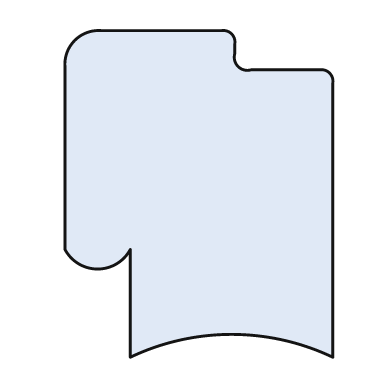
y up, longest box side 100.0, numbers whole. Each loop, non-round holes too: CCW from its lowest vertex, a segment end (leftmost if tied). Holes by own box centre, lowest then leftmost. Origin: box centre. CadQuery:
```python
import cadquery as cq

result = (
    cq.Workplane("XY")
    .moveTo(-21.0, -50.0)
    .threePointArc((10.0, -43.0), (41.0, -50.0))
    .lineTo(41.0, 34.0)
    .threePointArc((40.0, 37.0), (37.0, 38.0))
    .lineTo(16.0, 38.0)
    .threePointArc((12.0, 39.0), (11.0, 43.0))
    .lineTo(11.0, 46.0)
    .threePointArc((10.0, 49.0), (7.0, 50.0))
    .lineTo(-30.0, 50.0)
    .threePointArc((-38.0, 47.0), (-41.0, 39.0))
    .lineTo(-41.0, -17.0)
    .threePointArc((-31.0, -23.0), (-21.0, -17.0))
    .close()
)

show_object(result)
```